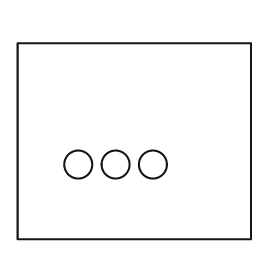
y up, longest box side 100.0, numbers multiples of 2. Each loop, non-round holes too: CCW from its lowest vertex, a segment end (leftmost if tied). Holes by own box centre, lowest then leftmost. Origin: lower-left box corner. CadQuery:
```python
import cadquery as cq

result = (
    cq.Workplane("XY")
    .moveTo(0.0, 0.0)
    .lineTo(100.0, 0.0)
    .lineTo(100.0, 84.0)
    .lineTo(0.0, 84.0)
    .close()
    .moveTo(26.0, 32.0)
    .circle(6.0)
    .moveTo(42.0, 32.0)
    .circle(6.0)
    .moveTo(58.0, 32.0)
    .circle(6.0)
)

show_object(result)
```